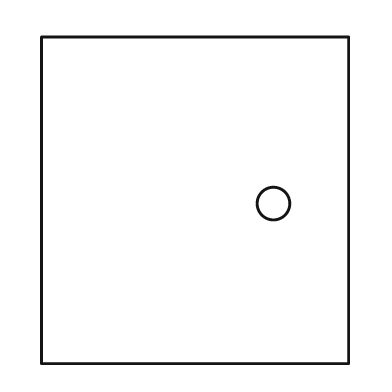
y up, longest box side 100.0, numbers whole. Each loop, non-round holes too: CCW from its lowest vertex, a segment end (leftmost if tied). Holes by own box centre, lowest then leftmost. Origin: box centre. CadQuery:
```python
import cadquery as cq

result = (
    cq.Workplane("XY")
    .moveTo(-47.0, -50.0)
    .lineTo(47.0, -50.0)
    .lineTo(47.0, 50.0)
    .lineTo(-47.0, 50.0)
    .close()
    .moveTo(24.0, -1.0)
    .circle(5.0)
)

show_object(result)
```